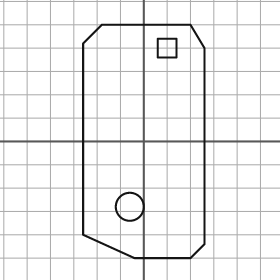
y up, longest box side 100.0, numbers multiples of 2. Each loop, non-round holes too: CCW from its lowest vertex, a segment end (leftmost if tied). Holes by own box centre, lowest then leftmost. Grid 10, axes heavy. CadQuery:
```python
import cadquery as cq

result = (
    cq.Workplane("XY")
    .moveTo(-4.0, -50.0)
    .lineTo(20.0, -50.0)
    .lineTo(26.0, -44.0)
    .lineTo(26.0, 40.0)
    .lineTo(20.0, 50.0)
    .lineTo(-18.0, 50.0)
    .lineTo(-26.0, 42.0)
    .lineTo(-26.0, -40.0)
    .close()
    .moveTo(-6.0, -28.0)
    .circle(6.0)
    .moveTo(6.0, 36.0)
    .lineTo(14.0, 36.0)
    .lineTo(14.0, 44.0)
    .lineTo(6.0, 44.0)
    .close()
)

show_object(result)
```